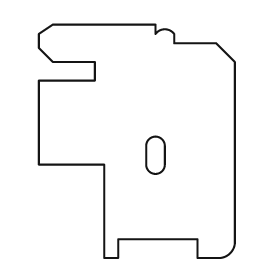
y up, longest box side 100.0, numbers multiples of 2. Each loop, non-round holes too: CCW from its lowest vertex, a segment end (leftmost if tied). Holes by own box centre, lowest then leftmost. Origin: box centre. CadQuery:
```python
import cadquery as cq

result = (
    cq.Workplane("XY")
    .moveTo(-14.0, -50.0)
    .lineTo(-8.0, -50.0)
    .lineTo(-8.0, -42.0)
    .lineTo(26.0, -42.0)
    .lineTo(26.0, -50.0)
    .lineTo(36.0, -50.0)
    .threePointArc((40.0, -48.0), (42.0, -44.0))
    .lineTo(42.0, 34.0)
    .lineTo(34.0, 42.0)
    .lineTo(16.0, 42.0)
    .lineTo(16.0, 46.0)
    .threePointArc((12.0, 48.0), (8.0, 46.0))
    .lineTo(8.0, 50.0)
    .lineTo(-36.0, 50.0)
    .lineTo(-42.0, 46.0)
    .lineTo(-42.0, 40.0)
    .lineTo(-36.0, 34.0)
    .lineTo(-18.0, 34.0)
    .lineTo(-18.0, 26.0)
    .lineTo(-42.0, 26.0)
    .lineTo(-42.0, -10.0)
    .lineTo(-14.0, -10.0)
    .close()
    .moveTo(4.0, -10.0)
    .threePointArc((8.0, -14.0), (12.0, -10.0))
    .lineTo(12.0, -2.0)
    .threePointArc((8.0, 2.0), (4.0, -2.0))
    .close()
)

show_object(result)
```